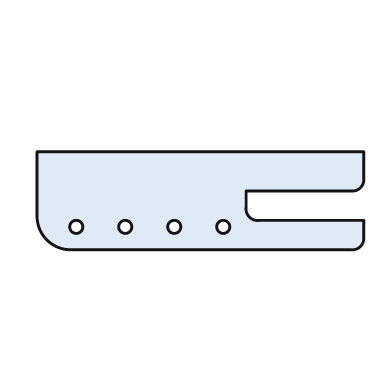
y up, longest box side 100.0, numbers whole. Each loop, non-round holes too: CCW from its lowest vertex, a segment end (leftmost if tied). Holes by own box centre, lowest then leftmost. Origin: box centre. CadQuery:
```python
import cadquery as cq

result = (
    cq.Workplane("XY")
    .moveTo(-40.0, -15.0)
    .lineTo(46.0, -15.0)
    .threePointArc((49.0, -14.0), (50.0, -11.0))
    .lineTo(50.0, -6.0)
    .lineTo(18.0, -6.0)
    .threePointArc((15.0, -5.0), (14.0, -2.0))
    .lineTo(14.0, 3.0)
    .lineTo(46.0, 3.0)
    .threePointArc((49.0, 4.0), (50.0, 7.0))
    .lineTo(50.0, 15.0)
    .lineTo(-50.0, 15.0)
    .lineTo(-50.0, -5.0)
    .threePointArc((-47.0, -12.0), (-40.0, -15.0))
    .close()
    .moveTo(-38.0, -8.0)
    .circle(2.0)
    .moveTo(-23.0, -8.0)
    .circle(2.0)
    .moveTo(-8.0, -8.0)
    .circle(2.0)
    .moveTo(7.0, -8.0)
    .circle(2.0)
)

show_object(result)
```